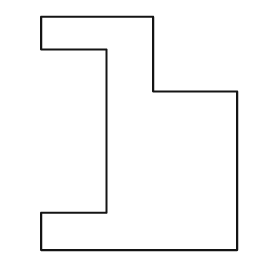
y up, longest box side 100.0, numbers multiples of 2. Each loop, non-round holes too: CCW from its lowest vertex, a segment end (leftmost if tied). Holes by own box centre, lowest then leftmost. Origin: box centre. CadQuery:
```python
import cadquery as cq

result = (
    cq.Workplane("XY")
    .moveTo(-42.0, -50.0)
    .lineTo(42.0, -50.0)
    .lineTo(42.0, 18.0)
    .lineTo(6.0, 18.0)
    .lineTo(6.0, 50.0)
    .lineTo(-42.0, 50.0)
    .lineTo(-42.0, 36.0)
    .lineTo(-14.0, 36.0)
    .lineTo(-14.0, -34.0)
    .lineTo(-42.0, -34.0)
    .close()
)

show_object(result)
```